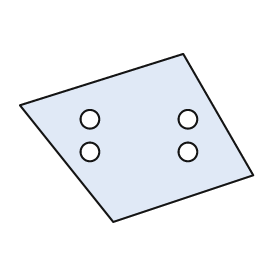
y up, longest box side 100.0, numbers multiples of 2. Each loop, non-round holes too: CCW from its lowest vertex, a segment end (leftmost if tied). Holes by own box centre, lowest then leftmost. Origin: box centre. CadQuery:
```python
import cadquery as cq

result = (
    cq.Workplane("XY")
    .moveTo(-10.0, -36.0)
    .lineTo(50.0, -16.0)
    .lineTo(20.0, 36.0)
    .lineTo(-50.0, 14.0)
    .close()
    .moveTo(-20.0, -6.0)
    .circle(4.0)
    .moveTo(22.0, -6.0)
    .circle(4.0)
    .moveTo(-20.0, 8.0)
    .circle(4.0)
    .moveTo(22.0, 8.0)
    .circle(4.0)
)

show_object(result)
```